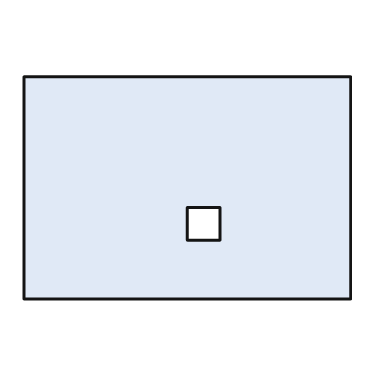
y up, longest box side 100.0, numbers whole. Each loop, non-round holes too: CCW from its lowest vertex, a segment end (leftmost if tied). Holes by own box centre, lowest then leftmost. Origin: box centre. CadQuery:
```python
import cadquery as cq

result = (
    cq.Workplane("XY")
    .moveTo(-50.0, -34.0)
    .lineTo(50.0, -34.0)
    .lineTo(50.0, 34.0)
    .lineTo(-50.0, 34.0)
    .close()
    .moveTo(0.0, -16.0)
    .lineTo(10.0, -16.0)
    .lineTo(10.0, -6.0)
    .lineTo(0.0, -6.0)
    .close()
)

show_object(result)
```